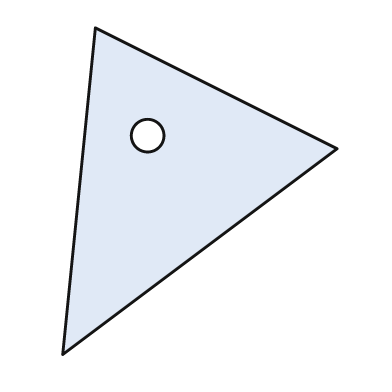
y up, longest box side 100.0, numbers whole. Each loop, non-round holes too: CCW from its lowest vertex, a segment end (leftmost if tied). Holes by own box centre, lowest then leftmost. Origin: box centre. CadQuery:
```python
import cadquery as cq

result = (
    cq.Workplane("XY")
    .moveTo(-42.0, -50.0)
    .lineTo(42.0, 13.0)
    .lineTo(-32.0, 50.0)
    .close()
    .moveTo(-16.0, 17.0)
    .circle(5.0)
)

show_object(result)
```